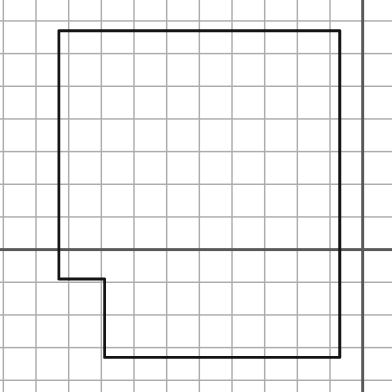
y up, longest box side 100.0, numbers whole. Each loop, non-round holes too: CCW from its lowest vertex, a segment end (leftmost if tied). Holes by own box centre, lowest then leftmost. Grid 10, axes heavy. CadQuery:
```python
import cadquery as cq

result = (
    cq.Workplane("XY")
    .moveTo(-79.0, -33.0)
    .lineTo(-7.0, -33.0)
    .lineTo(-7.0, 67.0)
    .lineTo(-93.0, 67.0)
    .lineTo(-93.0, -9.0)
    .lineTo(-79.0, -9.0)
    .close()
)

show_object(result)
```